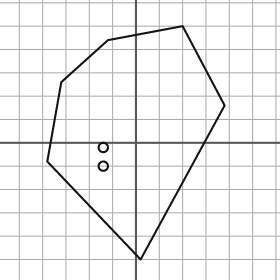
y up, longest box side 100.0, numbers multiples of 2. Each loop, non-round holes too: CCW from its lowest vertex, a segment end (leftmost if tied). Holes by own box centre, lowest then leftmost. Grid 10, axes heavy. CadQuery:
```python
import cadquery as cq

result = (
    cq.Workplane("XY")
    .moveTo(2.0, -50.0)
    .lineTo(38.0, 16.0)
    .lineTo(20.0, 50.0)
    .lineTo(-12.0, 44.0)
    .lineTo(-32.0, 26.0)
    .lineTo(-38.0, -8.0)
    .close()
    .moveTo(-14.0, -10.0)
    .circle(2.0)
    .moveTo(-14.0, -2.0)
    .circle(2.0)
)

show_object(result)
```